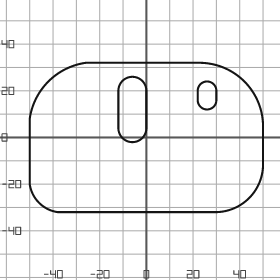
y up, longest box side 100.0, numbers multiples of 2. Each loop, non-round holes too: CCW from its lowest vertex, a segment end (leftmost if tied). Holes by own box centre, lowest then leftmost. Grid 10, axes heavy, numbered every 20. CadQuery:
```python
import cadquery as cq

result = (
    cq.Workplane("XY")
    .moveTo(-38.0, -32.0)
    .lineTo(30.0, -32.0)
    .threePointArc((44.0, -26.0), (50.0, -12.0))
    .lineTo(50.0, 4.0)
    .threePointArc((42.0, 24.0), (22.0, 32.0))
    .lineTo(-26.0, 32.0)
    .threePointArc((-42.0, 24.0), (-50.0, 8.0))
    .lineTo(-50.0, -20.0)
    .threePointArc((-46.0, -28.0), (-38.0, -32.0))
    .close()
    .moveTo(-12.0, 4.0)
    .threePointArc((-6.0, -2.0), (0.0, 4.0))
    .lineTo(0.0, 20.0)
    .threePointArc((-6.0, 26.0), (-12.0, 20.0))
    .close()
    .moveTo(22.0, 16.0)
    .threePointArc((26.0, 12.0), (30.0, 16.0))
    .lineTo(30.0, 20.0)
    .threePointArc((26.0, 24.0), (22.0, 20.0))
    .close()
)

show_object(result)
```